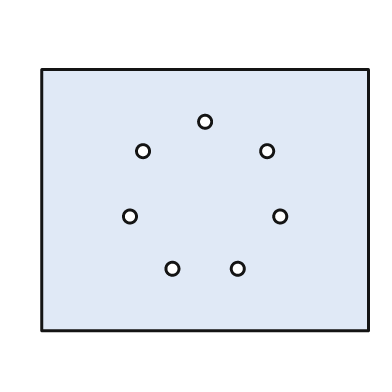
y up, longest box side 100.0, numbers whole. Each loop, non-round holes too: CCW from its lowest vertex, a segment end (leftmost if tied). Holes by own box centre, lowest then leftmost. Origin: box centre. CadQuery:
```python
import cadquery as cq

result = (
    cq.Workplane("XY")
    .moveTo(-50.0, -40.0)
    .lineTo(50.0, -40.0)
    .lineTo(50.0, 40.0)
    .lineTo(-50.0, 40.0)
    .close()
    .moveTo(-10.0, -21.0)
    .circle(2.0)
    .moveTo(10.0, -21.0)
    .circle(2.0)
    .moveTo(-23.0, -5.0)
    .circle(2.0)
    .moveTo(23.0, -5.0)
    .circle(2.0)
    .moveTo(-19.0, 15.0)
    .circle(2.0)
    .moveTo(19.0, 15.0)
    .circle(2.0)
    .moveTo(0.0, 24.0)
    .circle(2.0)
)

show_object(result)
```